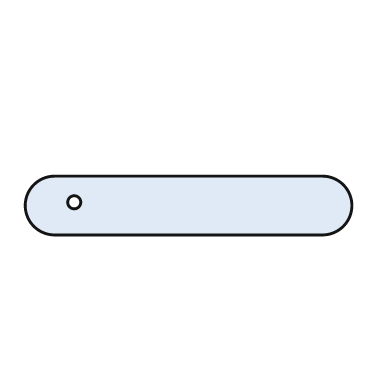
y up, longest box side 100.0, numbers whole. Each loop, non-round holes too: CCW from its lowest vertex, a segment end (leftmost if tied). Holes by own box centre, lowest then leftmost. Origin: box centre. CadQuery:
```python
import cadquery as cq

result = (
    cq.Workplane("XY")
    .moveTo(-41.0, -9.0)
    .lineTo(41.0, -9.0)
    .threePointArc((50.0, 0.0), (41.0, 9.0))
    .lineTo(-41.0, 9.0)
    .threePointArc((-50.0, 0.0), (-41.0, -9.0))
    .close()
    .moveTo(-35.0, 1.0)
    .circle(2.0)
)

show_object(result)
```